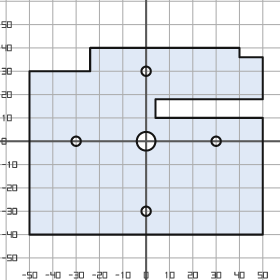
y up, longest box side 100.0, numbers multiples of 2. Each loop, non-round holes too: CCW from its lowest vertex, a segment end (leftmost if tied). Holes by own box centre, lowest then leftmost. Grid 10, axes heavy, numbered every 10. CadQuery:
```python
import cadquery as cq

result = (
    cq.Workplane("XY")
    .moveTo(-50.0, -40.0)
    .lineTo(50.0, -40.0)
    .lineTo(50.0, 10.0)
    .lineTo(4.0, 10.0)
    .lineTo(4.0, 18.0)
    .lineTo(50.0, 18.0)
    .lineTo(50.0, 36.0)
    .lineTo(40.0, 36.0)
    .lineTo(40.0, 40.0)
    .lineTo(-24.0, 40.0)
    .lineTo(-24.0, 30.0)
    .lineTo(-50.0, 30.0)
    .close()
    .moveTo(0.0, -30.0)
    .circle(2.0)
    .moveTo(-30.0, 0.0)
    .circle(2.0)
    .moveTo(0.0, 0.0)
    .circle(4.0)
    .moveTo(30.0, 0.0)
    .circle(2.0)
    .moveTo(0.0, 30.0)
    .circle(2.0)
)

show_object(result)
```